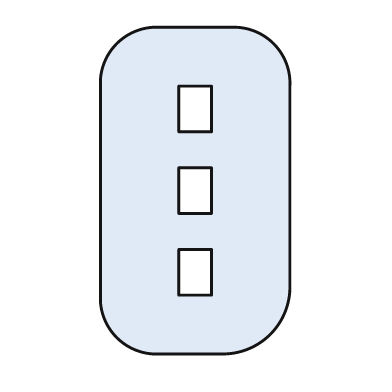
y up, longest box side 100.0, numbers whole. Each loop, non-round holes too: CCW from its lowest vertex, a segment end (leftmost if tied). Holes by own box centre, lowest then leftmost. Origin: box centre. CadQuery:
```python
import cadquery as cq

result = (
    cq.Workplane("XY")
    .moveTo(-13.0, -50.0)
    .lineTo(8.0, -50.0)
    .threePointArc((23.0, -44.0), (29.0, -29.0))
    .lineTo(29.0, 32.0)
    .threePointArc((24.0, 45.0), (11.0, 50.0))
    .lineTo(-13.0, 50.0)
    .threePointArc((-24.0, 45.0), (-29.0, 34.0))
    .lineTo(-29.0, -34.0)
    .threePointArc((-24.0, -45.0), (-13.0, -50.0))
    .close()
    .moveTo(-5.0, -32.0)
    .lineTo(5.0, -32.0)
    .lineTo(5.0, -18.0)
    .lineTo(-5.0, -18.0)
    .close()
    .moveTo(-5.0, -7.0)
    .lineTo(5.0, -7.0)
    .lineTo(5.0, 7.0)
    .lineTo(-5.0, 7.0)
    .close()
    .moveTo(-5.0, 18.0)
    .lineTo(5.0, 18.0)
    .lineTo(5.0, 32.0)
    .lineTo(-5.0, 32.0)
    .close()
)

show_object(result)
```